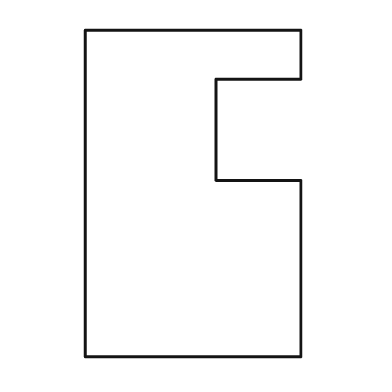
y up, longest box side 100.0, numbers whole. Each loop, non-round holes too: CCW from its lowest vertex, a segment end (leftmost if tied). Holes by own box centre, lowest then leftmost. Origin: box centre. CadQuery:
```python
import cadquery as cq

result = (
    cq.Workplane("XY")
    .moveTo(-33.0, -50.0)
    .lineTo(33.0, -50.0)
    .lineTo(33.0, 4.0)
    .lineTo(7.0, 4.0)
    .lineTo(7.0, 35.0)
    .lineTo(33.0, 35.0)
    .lineTo(33.0, 50.0)
    .lineTo(-33.0, 50.0)
    .close()
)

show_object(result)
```